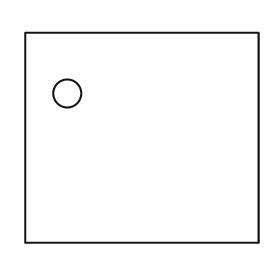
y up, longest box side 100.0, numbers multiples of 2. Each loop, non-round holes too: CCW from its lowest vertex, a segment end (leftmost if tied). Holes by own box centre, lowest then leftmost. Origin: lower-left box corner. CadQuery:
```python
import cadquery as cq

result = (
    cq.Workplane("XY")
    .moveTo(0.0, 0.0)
    .lineTo(100.0, 0.0)
    .lineTo(100.0, 90.0)
    .lineTo(0.0, 90.0)
    .close()
    .moveTo(18.0, 64.0)
    .circle(6.0)
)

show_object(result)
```